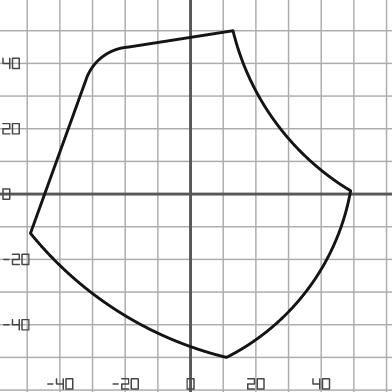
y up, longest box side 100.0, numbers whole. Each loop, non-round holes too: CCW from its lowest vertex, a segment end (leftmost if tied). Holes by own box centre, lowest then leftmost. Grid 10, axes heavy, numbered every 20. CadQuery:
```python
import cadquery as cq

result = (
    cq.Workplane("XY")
    .moveTo(11.0, -50.0)
    .threePointArc((36.0, -29.0), (49.0, 1.0))
    .threePointArc((26.0, 22.0), (13.0, 50.0))
    .lineTo(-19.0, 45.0)
    .threePointArc((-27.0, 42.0), (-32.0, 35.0))
    .lineTo(-49.0, -12.0)
    .threePointArc((-22.0, -36.0), (11.0, -50.0))
    .close()
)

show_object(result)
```